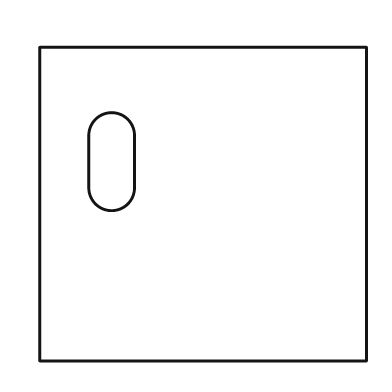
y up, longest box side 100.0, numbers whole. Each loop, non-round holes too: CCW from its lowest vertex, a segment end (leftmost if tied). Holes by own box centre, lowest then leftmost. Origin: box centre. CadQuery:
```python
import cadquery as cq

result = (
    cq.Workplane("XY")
    .moveTo(-50.0, -48.0)
    .lineTo(50.0, -48.0)
    .lineTo(50.0, 48.0)
    .lineTo(-50.0, 48.0)
    .close()
    .moveTo(-35.0, 5.0)
    .threePointArc((-28.0, -2.0), (-21.0, 5.0))
    .lineTo(-21.0, 21.0)
    .threePointArc((-28.0, 28.0), (-35.0, 21.0))
    .close()
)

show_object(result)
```